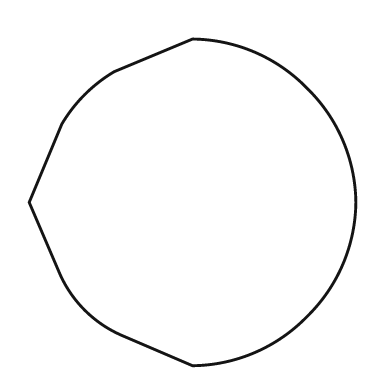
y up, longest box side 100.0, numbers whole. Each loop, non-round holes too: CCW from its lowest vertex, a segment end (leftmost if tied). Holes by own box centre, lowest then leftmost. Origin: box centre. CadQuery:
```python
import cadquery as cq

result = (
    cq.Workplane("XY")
    .moveTo(0.0, -50.0)
    .threePointArc((19.0, -46.0), (35.0, -35.0))
    .threePointArc((46.0, -19.0), (50.0, 0.0))
    .threePointArc((46.0, 19.0), (35.0, 35.0))
    .threePointArc((19.0, 46.0), (0.0, 50.0))
    .lineTo(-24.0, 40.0)
    .threePointArc((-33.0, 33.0), (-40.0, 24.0))
    .lineTo(-50.0, 0.0)
    .lineTo(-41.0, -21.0)
    .threePointArc((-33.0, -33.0), (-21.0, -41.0))
    .close()
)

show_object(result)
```